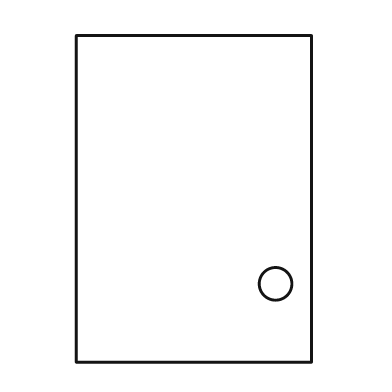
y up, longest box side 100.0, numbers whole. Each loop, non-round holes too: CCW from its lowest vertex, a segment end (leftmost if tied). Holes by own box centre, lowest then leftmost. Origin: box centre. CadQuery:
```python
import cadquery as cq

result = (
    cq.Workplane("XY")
    .moveTo(-36.0, -50.0)
    .lineTo(36.0, -50.0)
    .lineTo(36.0, 50.0)
    .lineTo(-36.0, 50.0)
    .close()
    .moveTo(25.0, -26.0)
    .circle(5.0)
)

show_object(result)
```